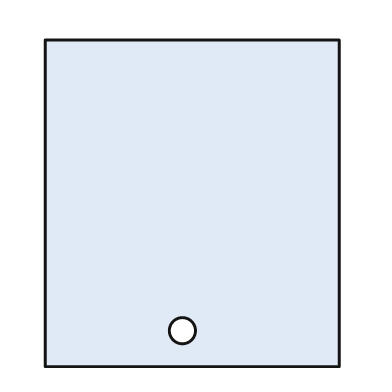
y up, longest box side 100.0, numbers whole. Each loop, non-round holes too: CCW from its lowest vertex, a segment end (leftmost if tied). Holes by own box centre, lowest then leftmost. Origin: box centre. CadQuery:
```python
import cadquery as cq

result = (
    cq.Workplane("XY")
    .moveTo(-45.0, -50.0)
    .lineTo(45.0, -50.0)
    .lineTo(45.0, 50.0)
    .lineTo(-45.0, 50.0)
    .close()
    .moveTo(-3.0, -39.0)
    .circle(4.0)
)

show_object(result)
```